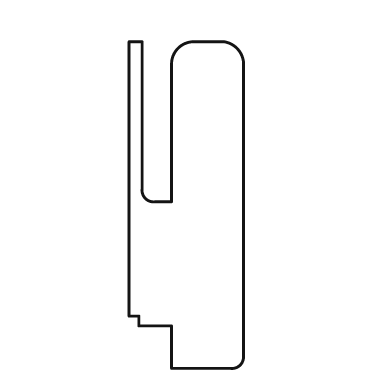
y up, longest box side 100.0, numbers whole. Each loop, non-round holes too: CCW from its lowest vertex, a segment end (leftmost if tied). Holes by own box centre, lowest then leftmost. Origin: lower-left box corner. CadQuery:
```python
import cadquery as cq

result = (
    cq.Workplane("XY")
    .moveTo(13.0, 0.0)
    .lineTo(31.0, 0.0)
    .threePointArc((34.0, 1.0), (35.0, 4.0))
    .lineTo(35.0, 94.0)
    .threePointArc((33.0, 98.0), (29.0, 100.0))
    .lineTo(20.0, 100.0)
    .threePointArc((15.0, 98.0), (13.0, 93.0))
    .lineTo(13.0, 51.0)
    .lineTo(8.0, 51.0)
    .threePointArc((5.0, 52.0), (4.0, 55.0))
    .lineTo(4.0, 100.0)
    .lineTo(0.0, 100.0)
    .lineTo(0.0, 16.0)
    .lineTo(3.0, 16.0)
    .lineTo(3.0, 13.0)
    .lineTo(13.0, 13.0)
    .close()
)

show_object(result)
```